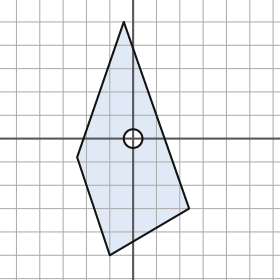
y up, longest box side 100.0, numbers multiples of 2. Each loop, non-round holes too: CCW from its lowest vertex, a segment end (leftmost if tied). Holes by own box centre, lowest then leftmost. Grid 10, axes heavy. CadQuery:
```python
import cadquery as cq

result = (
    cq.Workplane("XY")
    .moveTo(-10.0, -50.0)
    .lineTo(24.0, -30.0)
    .lineTo(-4.0, 50.0)
    .lineTo(-24.0, -8.0)
    .close()
    .moveTo(0.0, 0.0)
    .circle(4.0)
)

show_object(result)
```